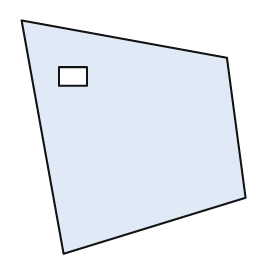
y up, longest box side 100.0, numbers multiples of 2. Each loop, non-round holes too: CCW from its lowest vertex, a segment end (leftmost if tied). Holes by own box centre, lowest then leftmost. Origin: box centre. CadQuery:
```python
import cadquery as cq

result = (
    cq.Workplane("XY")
    .moveTo(-30.0, -50.0)
    .lineTo(48.0, -26.0)
    .lineTo(40.0, 34.0)
    .lineTo(-48.0, 50.0)
    .close()
    .moveTo(-32.0, 22.0)
    .lineTo(-20.0, 22.0)
    .lineTo(-20.0, 30.0)
    .lineTo(-32.0, 30.0)
    .close()
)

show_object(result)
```